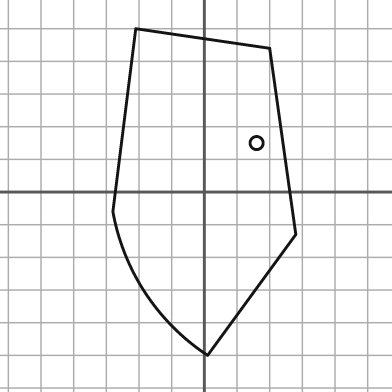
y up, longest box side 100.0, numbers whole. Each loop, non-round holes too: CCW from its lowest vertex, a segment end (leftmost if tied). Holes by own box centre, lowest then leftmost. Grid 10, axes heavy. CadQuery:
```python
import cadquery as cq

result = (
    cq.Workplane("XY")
    .moveTo(1.0, -50.0)
    .lineTo(28.0, -13.0)
    .lineTo(20.0, 44.0)
    .lineTo(-21.0, 50.0)
    .lineTo(-28.0, -6.0)
    .threePointArc((-18.0, -31.0), (1.0, -50.0))
    .close()
    .moveTo(16.0, 15.0)
    .circle(2.0)
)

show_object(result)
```